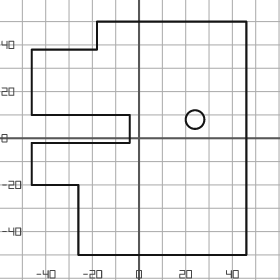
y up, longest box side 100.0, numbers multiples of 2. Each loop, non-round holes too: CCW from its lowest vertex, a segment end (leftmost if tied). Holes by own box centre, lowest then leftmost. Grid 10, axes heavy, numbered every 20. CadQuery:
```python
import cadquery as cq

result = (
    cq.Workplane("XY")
    .moveTo(-26.0, -50.0)
    .lineTo(46.0, -50.0)
    .lineTo(46.0, 50.0)
    .lineTo(-18.0, 50.0)
    .lineTo(-18.0, 38.0)
    .lineTo(-46.0, 38.0)
    .lineTo(-46.0, 10.0)
    .lineTo(-4.0, 10.0)
    .lineTo(-4.0, -2.0)
    .lineTo(-46.0, -2.0)
    .lineTo(-46.0, -20.0)
    .lineTo(-26.0, -20.0)
    .close()
    .moveTo(24.0, 8.0)
    .circle(4.0)
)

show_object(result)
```